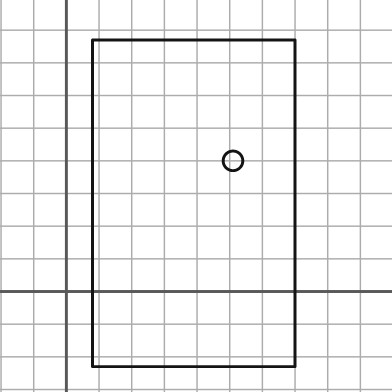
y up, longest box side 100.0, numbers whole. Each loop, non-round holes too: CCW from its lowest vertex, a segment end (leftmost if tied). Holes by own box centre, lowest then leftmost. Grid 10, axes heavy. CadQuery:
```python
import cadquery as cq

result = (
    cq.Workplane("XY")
    .moveTo(8.0, -23.0)
    .lineTo(70.0, -23.0)
    .lineTo(70.0, 77.0)
    .lineTo(8.0, 77.0)
    .close()
    .moveTo(51.0, 40.0)
    .circle(3.0)
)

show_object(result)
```